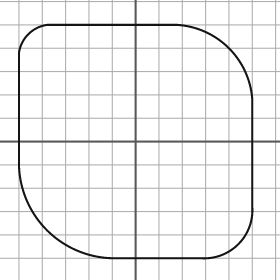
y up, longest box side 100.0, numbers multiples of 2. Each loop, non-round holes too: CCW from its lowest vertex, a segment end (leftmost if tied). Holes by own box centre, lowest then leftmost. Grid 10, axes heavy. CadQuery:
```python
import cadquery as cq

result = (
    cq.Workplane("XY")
    .moveTo(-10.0, -50.0)
    .lineTo(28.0, -50.0)
    .threePointArc((44.0, -44.0), (50.0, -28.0))
    .lineTo(50.0, 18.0)
    .threePointArc((40.0, 40.0), (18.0, 50.0))
    .lineTo(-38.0, 50.0)
    .threePointArc((-46.0, 46.0), (-50.0, 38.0))
    .lineTo(-50.0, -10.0)
    .threePointArc((-38.0, -38.0), (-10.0, -50.0))
    .close()
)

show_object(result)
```